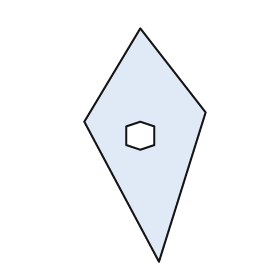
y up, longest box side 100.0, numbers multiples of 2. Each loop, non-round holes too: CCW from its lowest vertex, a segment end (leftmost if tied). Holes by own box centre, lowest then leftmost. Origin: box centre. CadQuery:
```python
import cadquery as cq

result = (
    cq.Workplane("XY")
    .moveTo(6.0, -50.0)
    .lineTo(26.0, 14.0)
    .lineTo(-2.0, 50.0)
    .lineTo(-26.0, 10.0)
    .close()
    .moveTo(-2.0, -2.0)
    .lineTo(4.0, 0.0)
    .lineTo(4.0, 8.0)
    .lineTo(-2.0, 10.0)
    .lineTo(-8.0, 8.0)
    .lineTo(-8.0, 0.0)
    .close()
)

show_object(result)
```